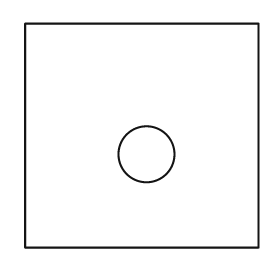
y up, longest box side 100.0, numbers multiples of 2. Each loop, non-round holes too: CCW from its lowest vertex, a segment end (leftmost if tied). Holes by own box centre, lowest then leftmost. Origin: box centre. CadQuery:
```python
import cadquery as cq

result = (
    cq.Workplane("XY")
    .moveTo(-50.0, -48.0)
    .lineTo(50.0, -48.0)
    .lineTo(50.0, 48.0)
    .lineTo(-50.0, 48.0)
    .close()
    .moveTo(2.0, -8.0)
    .circle(12.0)
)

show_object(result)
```